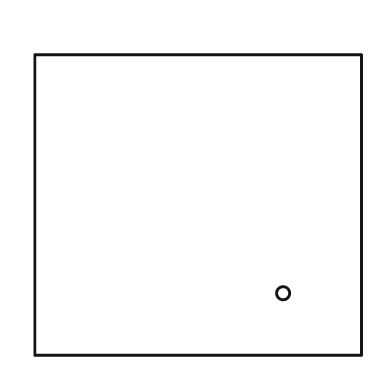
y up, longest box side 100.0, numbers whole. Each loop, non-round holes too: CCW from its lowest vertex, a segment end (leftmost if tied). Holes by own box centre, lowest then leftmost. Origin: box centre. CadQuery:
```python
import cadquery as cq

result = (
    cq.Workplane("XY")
    .moveTo(-50.0, -46.0)
    .lineTo(50.0, -46.0)
    .lineTo(50.0, 46.0)
    .lineTo(-50.0, 46.0)
    .close()
    .moveTo(26.0, -27.0)
    .circle(2.0)
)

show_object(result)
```